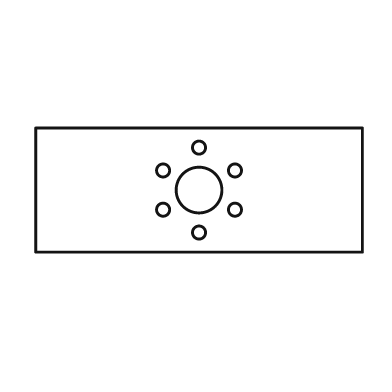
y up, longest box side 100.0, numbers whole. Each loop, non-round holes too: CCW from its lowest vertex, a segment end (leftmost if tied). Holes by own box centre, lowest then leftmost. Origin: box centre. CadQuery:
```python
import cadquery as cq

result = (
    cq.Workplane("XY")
    .moveTo(-50.0, -19.0)
    .lineTo(50.0, -19.0)
    .lineTo(50.0, 19.0)
    .lineTo(-50.0, 19.0)
    .close()
    .moveTo(0.0, -13.0)
    .circle(2.0)
    .moveTo(-11.0, -6.0)
    .circle(2.0)
    .moveTo(11.0, -6.0)
    .circle(2.0)
    .moveTo(0.0, 0.0)
    .circle(7.0)
    .moveTo(-11.0, 6.0)
    .circle(2.0)
    .moveTo(11.0, 6.0)
    .circle(2.0)
    .moveTo(0.0, 13.0)
    .circle(2.0)
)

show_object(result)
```